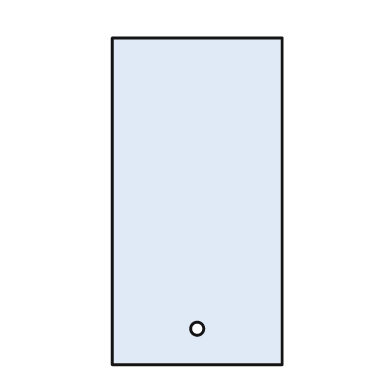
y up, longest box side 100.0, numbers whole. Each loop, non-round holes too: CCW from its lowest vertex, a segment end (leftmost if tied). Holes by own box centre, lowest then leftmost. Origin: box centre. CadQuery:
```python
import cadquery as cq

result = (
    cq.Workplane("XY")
    .moveTo(-26.0, -50.0)
    .lineTo(26.0, -50.0)
    .lineTo(26.0, 50.0)
    .lineTo(-26.0, 50.0)
    .close()
    .moveTo(0.0, -39.0)
    .circle(2.0)
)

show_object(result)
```